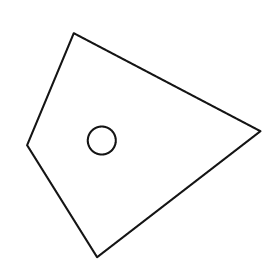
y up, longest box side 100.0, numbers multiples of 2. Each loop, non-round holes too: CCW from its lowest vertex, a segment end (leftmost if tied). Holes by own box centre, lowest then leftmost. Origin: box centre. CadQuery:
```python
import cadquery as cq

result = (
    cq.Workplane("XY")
    .moveTo(-20.0, -48.0)
    .lineTo(50.0, 6.0)
    .lineTo(-30.0, 48.0)
    .lineTo(-50.0, 0.0)
    .close()
    .moveTo(-18.0, 2.0)
    .circle(6.0)
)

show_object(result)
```